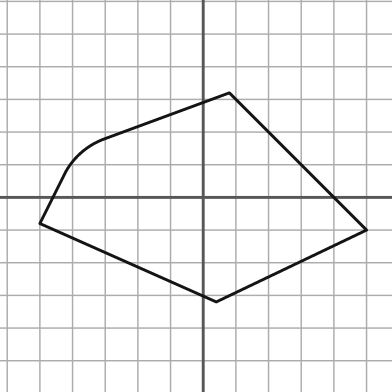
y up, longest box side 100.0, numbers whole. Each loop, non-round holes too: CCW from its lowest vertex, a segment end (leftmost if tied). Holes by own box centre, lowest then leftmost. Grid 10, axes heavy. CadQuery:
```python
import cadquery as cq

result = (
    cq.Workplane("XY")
    .moveTo(4.0, -32.0)
    .lineTo(50.0, -10.0)
    .lineTo(8.0, 32.0)
    .lineTo(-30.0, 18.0)
    .threePointArc((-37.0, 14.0), (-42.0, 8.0))
    .lineTo(-50.0, -8.0)
    .close()
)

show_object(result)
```